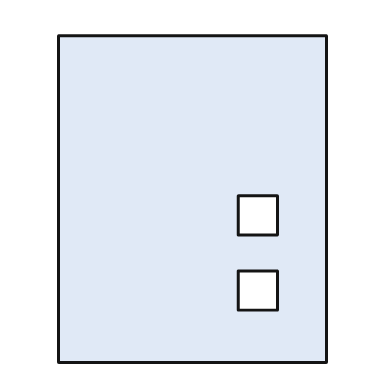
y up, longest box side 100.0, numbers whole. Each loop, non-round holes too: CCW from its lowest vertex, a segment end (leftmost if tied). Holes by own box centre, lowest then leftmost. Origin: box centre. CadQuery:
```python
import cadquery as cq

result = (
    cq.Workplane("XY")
    .moveTo(-41.0, -50.0)
    .lineTo(41.0, -50.0)
    .lineTo(41.0, 50.0)
    .lineTo(-41.0, 50.0)
    .close()
    .moveTo(14.0, -34.0)
    .lineTo(26.0, -34.0)
    .lineTo(26.0, -22.0)
    .lineTo(14.0, -22.0)
    .close()
    .moveTo(14.0, -11.0)
    .lineTo(26.0, -11.0)
    .lineTo(26.0, 1.0)
    .lineTo(14.0, 1.0)
    .close()
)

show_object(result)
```